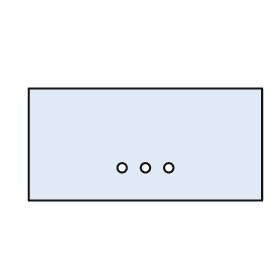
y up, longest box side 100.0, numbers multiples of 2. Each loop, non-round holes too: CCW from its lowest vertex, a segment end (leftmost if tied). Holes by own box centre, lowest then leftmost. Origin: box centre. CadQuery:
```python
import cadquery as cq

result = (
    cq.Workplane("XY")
    .moveTo(-50.0, -24.0)
    .lineTo(50.0, -24.0)
    .lineTo(50.0, 24.0)
    .lineTo(-50.0, 24.0)
    .close()
    .moveTo(-10.0, -10.0)
    .circle(2.0)
    .moveTo(0.0, -10.0)
    .circle(2.0)
    .moveTo(10.0, -10.0)
    .circle(2.0)
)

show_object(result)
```